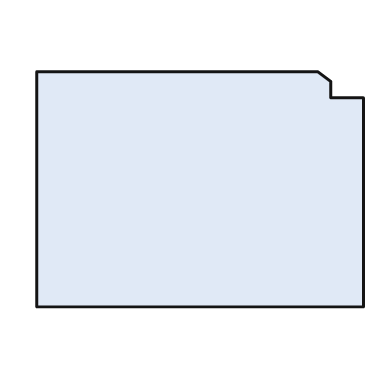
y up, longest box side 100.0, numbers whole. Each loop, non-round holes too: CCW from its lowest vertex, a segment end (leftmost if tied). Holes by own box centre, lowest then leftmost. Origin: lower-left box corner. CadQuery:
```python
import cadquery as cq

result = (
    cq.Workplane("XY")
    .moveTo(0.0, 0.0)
    .lineTo(100.0, 0.0)
    .lineTo(100.0, 64.0)
    .lineTo(90.0, 64.0)
    .lineTo(90.0, 69.0)
    .lineTo(86.0, 72.0)
    .lineTo(0.0, 72.0)
    .close()
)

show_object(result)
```